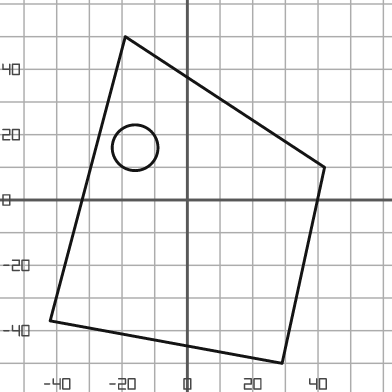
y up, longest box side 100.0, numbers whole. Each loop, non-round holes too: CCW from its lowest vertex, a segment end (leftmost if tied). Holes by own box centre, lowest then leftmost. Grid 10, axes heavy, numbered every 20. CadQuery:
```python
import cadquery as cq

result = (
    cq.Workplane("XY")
    .moveTo(29.0, -50.0)
    .lineTo(42.0, 10.0)
    .lineTo(-19.0, 50.0)
    .lineTo(-42.0, -37.0)
    .close()
    .moveTo(-16.0, 16.0)
    .circle(7.0)
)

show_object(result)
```